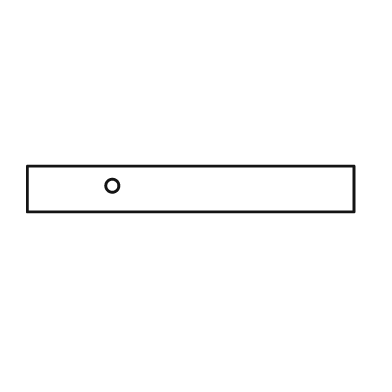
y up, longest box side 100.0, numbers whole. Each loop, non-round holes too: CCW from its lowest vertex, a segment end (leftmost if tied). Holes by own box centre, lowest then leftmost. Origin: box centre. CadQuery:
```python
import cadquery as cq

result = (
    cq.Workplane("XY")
    .moveTo(-50.0, -7.0)
    .lineTo(50.0, -7.0)
    .lineTo(50.0, 7.0)
    .lineTo(-50.0, 7.0)
    .close()
    .moveTo(-24.0, 1.0)
    .circle(2.0)
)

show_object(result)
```